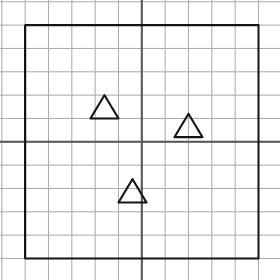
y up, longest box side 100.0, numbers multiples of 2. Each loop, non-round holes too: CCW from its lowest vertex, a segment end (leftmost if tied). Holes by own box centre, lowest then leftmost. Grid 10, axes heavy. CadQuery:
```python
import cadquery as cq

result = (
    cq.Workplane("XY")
    .moveTo(-50.0, -50.0)
    .lineTo(50.0, -50.0)
    .lineTo(50.0, 50.0)
    .lineTo(-50.0, 50.0)
    .close()
    .moveTo(-10.0, -26.0)
    .lineTo(2.0, -26.0)
    .lineTo(-4.0, -16.0)
    .close()
    .moveTo(14.0, 2.0)
    .lineTo(26.0, 2.0)
    .lineTo(20.0, 12.0)
    .close()
    .moveTo(-22.0, 10.0)
    .lineTo(-10.0, 10.0)
    .lineTo(-16.0, 20.0)
    .close()
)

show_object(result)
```